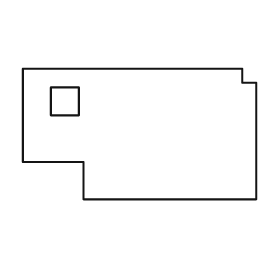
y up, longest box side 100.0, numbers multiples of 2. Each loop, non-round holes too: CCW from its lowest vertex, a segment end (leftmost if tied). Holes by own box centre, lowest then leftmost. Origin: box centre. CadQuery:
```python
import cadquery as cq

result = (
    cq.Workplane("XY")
    .moveTo(-24.0, -28.0)
    .lineTo(50.0, -28.0)
    .lineTo(50.0, 22.0)
    .lineTo(44.0, 22.0)
    .lineTo(44.0, 28.0)
    .lineTo(-50.0, 28.0)
    .lineTo(-50.0, -12.0)
    .lineTo(-24.0, -12.0)
    .close()
    .moveTo(-38.0, 8.0)
    .lineTo(-26.0, 8.0)
    .lineTo(-26.0, 20.0)
    .lineTo(-38.0, 20.0)
    .close()
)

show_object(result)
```